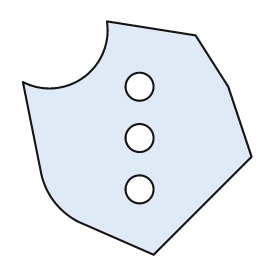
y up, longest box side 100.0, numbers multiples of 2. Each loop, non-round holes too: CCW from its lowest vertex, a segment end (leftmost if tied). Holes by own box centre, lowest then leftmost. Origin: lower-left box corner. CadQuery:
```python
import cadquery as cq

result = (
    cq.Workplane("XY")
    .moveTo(56.0, 0.0)
    .lineTo(98.0, 42.0)
    .lineTo(88.0, 72.0)
    .lineTo(74.0, 94.0)
    .lineTo(36.0, 100.0)
    .threePointArc((26.0, 76.0), (0.0, 74.0))
    .lineTo(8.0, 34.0)
    .threePointArc((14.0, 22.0), (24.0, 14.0))
    .close()
    .moveTo(50.0, 28.0)
    .circle(6.0)
    .moveTo(50.0, 50.0)
    .circle(6.0)
    .moveTo(50.0, 72.0)
    .circle(6.0)
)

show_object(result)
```